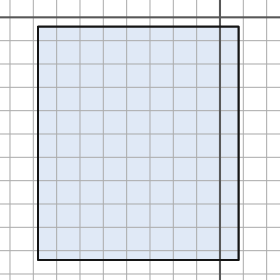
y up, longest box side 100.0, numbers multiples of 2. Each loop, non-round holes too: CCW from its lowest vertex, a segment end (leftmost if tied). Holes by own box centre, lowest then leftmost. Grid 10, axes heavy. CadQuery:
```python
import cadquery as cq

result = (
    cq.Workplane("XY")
    .moveTo(-78.0, -104.0)
    .lineTo(8.0, -104.0)
    .lineTo(8.0, -4.0)
    .lineTo(-78.0, -4.0)
    .close()
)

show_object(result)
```